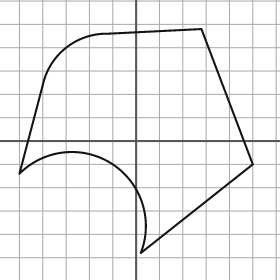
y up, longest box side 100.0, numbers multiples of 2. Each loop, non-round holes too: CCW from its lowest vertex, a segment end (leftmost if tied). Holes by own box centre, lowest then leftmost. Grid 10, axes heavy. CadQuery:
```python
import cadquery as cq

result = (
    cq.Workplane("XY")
    .moveTo(2.0, -48.0)
    .lineTo(50.0, -10.0)
    .lineTo(28.0, 48.0)
    .lineTo(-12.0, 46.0)
    .threePointArc((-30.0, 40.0), (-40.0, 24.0))
    .lineTo(-50.0, -14.0)
    .threePointArc((-10.0, -10.0), (2.0, -48.0))
    .close()
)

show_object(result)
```